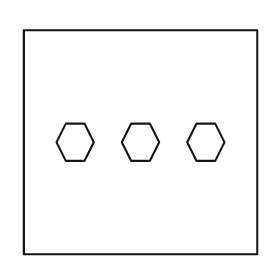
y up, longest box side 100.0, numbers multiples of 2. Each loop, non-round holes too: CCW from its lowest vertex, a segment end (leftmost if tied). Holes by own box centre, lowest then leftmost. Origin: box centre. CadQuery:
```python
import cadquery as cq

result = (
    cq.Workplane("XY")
    .moveTo(-50.0, -48.0)
    .lineTo(50.0, -48.0)
    .lineTo(50.0, 48.0)
    .lineTo(-50.0, 48.0)
    .close()
    .moveTo(-32.0, -8.0)
    .lineTo(-24.0, -8.0)
    .lineTo(-20.0, 0.0)
    .lineTo(-24.0, 8.0)
    .lineTo(-32.0, 8.0)
    .lineTo(-36.0, 0.0)
    .close()
    .moveTo(-4.0, -8.0)
    .lineTo(4.0, -8.0)
    .lineTo(8.0, 0.0)
    .lineTo(4.0, 8.0)
    .lineTo(-4.0, 8.0)
    .lineTo(-8.0, 0.0)
    .close()
    .moveTo(24.0, -8.0)
    .lineTo(32.0, -8.0)
    .lineTo(36.0, 0.0)
    .lineTo(32.0, 8.0)
    .lineTo(24.0, 8.0)
    .lineTo(20.0, 0.0)
    .close()
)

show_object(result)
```